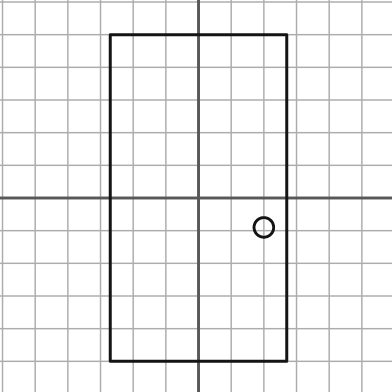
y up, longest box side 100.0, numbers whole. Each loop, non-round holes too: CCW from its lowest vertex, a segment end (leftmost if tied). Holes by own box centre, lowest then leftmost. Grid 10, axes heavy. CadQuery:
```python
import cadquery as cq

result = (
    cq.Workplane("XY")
    .moveTo(-27.0, -50.0)
    .lineTo(27.0, -50.0)
    .lineTo(27.0, 50.0)
    .lineTo(-27.0, 50.0)
    .close()
    .moveTo(20.0, -9.0)
    .circle(3.0)
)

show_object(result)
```